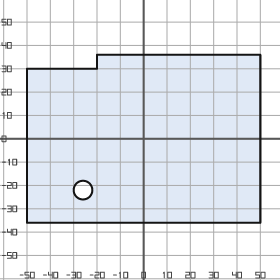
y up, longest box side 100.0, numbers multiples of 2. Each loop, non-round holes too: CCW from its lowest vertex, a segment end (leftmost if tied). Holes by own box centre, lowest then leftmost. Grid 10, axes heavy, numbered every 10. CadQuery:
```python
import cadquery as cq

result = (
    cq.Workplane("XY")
    .moveTo(-50.0, -36.0)
    .lineTo(50.0, -36.0)
    .lineTo(50.0, 36.0)
    .lineTo(-20.0, 36.0)
    .lineTo(-20.0, 30.0)
    .lineTo(-50.0, 30.0)
    .close()
    .moveTo(-26.0, -22.0)
    .circle(4.0)
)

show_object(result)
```